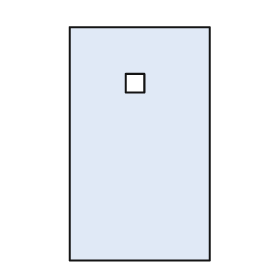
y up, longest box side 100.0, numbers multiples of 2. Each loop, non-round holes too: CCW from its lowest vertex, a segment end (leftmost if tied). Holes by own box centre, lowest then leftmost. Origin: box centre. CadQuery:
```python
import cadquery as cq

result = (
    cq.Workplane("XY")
    .moveTo(-30.0, -50.0)
    .lineTo(30.0, -50.0)
    .lineTo(30.0, 50.0)
    .lineTo(-30.0, 50.0)
    .close()
    .moveTo(-6.0, 22.0)
    .lineTo(2.0, 22.0)
    .lineTo(2.0, 30.0)
    .lineTo(-6.0, 30.0)
    .close()
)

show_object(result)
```